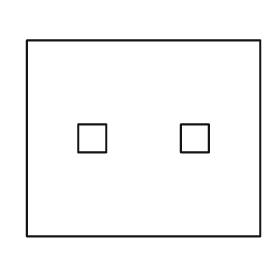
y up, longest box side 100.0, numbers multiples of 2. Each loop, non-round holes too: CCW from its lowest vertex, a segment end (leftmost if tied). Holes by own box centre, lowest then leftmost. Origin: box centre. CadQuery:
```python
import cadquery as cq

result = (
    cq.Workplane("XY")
    .moveTo(-50.0, -42.0)
    .lineTo(50.0, -42.0)
    .lineTo(50.0, 42.0)
    .lineTo(-50.0, 42.0)
    .close()
    .moveTo(-28.0, -6.0)
    .lineTo(-16.0, -6.0)
    .lineTo(-16.0, 6.0)
    .lineTo(-28.0, 6.0)
    .close()
    .moveTo(16.0, -6.0)
    .lineTo(28.0, -6.0)
    .lineTo(28.0, 6.0)
    .lineTo(16.0, 6.0)
    .close()
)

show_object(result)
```